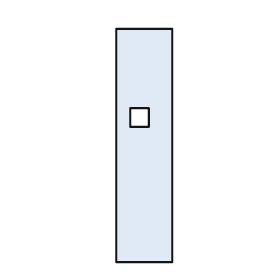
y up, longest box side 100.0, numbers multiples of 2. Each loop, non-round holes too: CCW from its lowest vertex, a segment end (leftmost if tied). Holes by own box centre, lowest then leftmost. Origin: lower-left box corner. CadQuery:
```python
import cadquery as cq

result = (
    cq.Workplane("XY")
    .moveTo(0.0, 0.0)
    .lineTo(24.0, 0.0)
    .lineTo(24.0, 100.0)
    .lineTo(0.0, 100.0)
    .close()
    .moveTo(6.0, 58.0)
    .lineTo(14.0, 58.0)
    .lineTo(14.0, 66.0)
    .lineTo(6.0, 66.0)
    .close()
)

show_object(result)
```